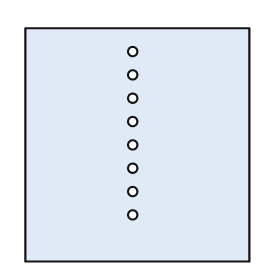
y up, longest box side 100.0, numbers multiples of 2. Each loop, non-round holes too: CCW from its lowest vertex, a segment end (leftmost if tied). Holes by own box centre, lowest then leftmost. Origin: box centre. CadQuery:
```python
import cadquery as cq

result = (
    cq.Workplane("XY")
    .moveTo(-48.0, -50.0)
    .lineTo(48.0, -50.0)
    .lineTo(48.0, 50.0)
    .lineTo(-48.0, 50.0)
    .close()
    .moveTo(-2.0, -30.0)
    .circle(2.0)
    .moveTo(-2.0, -20.0)
    .circle(2.0)
    .moveTo(-2.0, -10.0)
    .circle(2.0)
    .moveTo(-2.0, 0.0)
    .circle(2.0)
    .moveTo(-2.0, 10.0)
    .circle(2.0)
    .moveTo(-2.0, 20.0)
    .circle(2.0)
    .moveTo(-2.0, 30.0)
    .circle(2.0)
    .moveTo(-2.0, 40.0)
    .circle(2.0)
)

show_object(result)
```